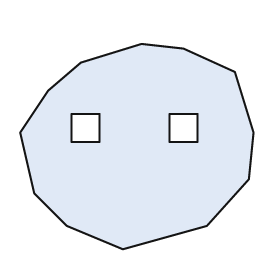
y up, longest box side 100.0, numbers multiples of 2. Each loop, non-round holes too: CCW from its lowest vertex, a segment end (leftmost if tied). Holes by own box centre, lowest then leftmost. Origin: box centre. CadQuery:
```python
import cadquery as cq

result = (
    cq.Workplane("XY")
    .moveTo(-6.0, -44.0)
    .lineTo(30.0, -34.0)
    .lineTo(48.0, -14.0)
    .lineTo(50.0, 6.0)
    .lineTo(42.0, 32.0)
    .lineTo(20.0, 42.0)
    .lineTo(2.0, 44.0)
    .lineTo(-24.0, 36.0)
    .lineTo(-38.0, 24.0)
    .lineTo(-50.0, 6.0)
    .lineTo(-44.0, -20.0)
    .lineTo(-30.0, -34.0)
    .close()
    .moveTo(-28.0, 2.0)
    .lineTo(-16.0, 2.0)
    .lineTo(-16.0, 14.0)
    .lineTo(-28.0, 14.0)
    .close()
    .moveTo(14.0, 2.0)
    .lineTo(26.0, 2.0)
    .lineTo(26.0, 14.0)
    .lineTo(14.0, 14.0)
    .close()
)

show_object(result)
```